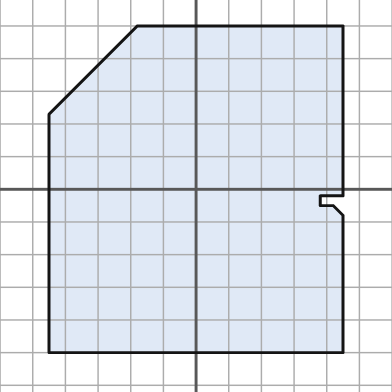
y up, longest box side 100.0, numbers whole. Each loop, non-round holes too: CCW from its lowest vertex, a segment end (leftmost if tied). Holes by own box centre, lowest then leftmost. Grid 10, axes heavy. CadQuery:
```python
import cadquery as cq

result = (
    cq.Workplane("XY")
    .moveTo(-45.0, -50.0)
    .lineTo(45.0, -50.0)
    .lineTo(45.0, -8.0)
    .lineTo(42.0, -5.0)
    .lineTo(38.0, -5.0)
    .lineTo(38.0, -2.0)
    .lineTo(45.0, -2.0)
    .lineTo(45.0, 50.0)
    .lineTo(-18.0, 50.0)
    .lineTo(-45.0, 23.0)
    .close()
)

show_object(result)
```